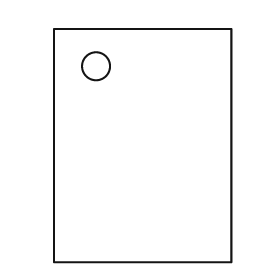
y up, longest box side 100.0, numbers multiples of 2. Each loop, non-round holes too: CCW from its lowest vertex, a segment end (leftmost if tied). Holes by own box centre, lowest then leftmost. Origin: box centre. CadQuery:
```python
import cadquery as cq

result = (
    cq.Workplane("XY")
    .moveTo(-38.0, -50.0)
    .lineTo(38.0, -50.0)
    .lineTo(38.0, 50.0)
    .lineTo(-38.0, 50.0)
    .close()
    .moveTo(-20.0, 34.0)
    .circle(6.0)
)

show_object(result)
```